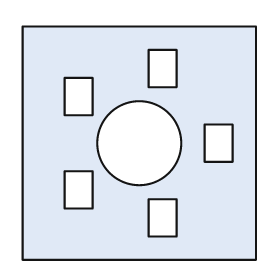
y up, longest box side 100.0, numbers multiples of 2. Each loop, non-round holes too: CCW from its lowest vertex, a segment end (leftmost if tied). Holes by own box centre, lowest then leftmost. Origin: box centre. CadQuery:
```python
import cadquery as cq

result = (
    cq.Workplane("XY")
    .moveTo(-50.0, -50.0)
    .lineTo(50.0, -50.0)
    .lineTo(50.0, 50.0)
    .lineTo(-50.0, 50.0)
    .close()
    .moveTo(4.0, -40.0)
    .lineTo(16.0, -40.0)
    .lineTo(16.0, -24.0)
    .lineTo(4.0, -24.0)
    .close()
    .moveTo(-32.0, -28.0)
    .lineTo(-20.0, -28.0)
    .lineTo(-20.0, -12.0)
    .lineTo(-32.0, -12.0)
    .close()
    .moveTo(0.0, 0.0)
    .circle(18.0)
    .moveTo(28.0, -8.0)
    .lineTo(40.0, -8.0)
    .lineTo(40.0, 8.0)
    .lineTo(28.0, 8.0)
    .close()
    .moveTo(-32.0, 12.0)
    .lineTo(-20.0, 12.0)
    .lineTo(-20.0, 28.0)
    .lineTo(-32.0, 28.0)
    .close()
    .moveTo(4.0, 24.0)
    .lineTo(16.0, 24.0)
    .lineTo(16.0, 40.0)
    .lineTo(4.0, 40.0)
    .close()
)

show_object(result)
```